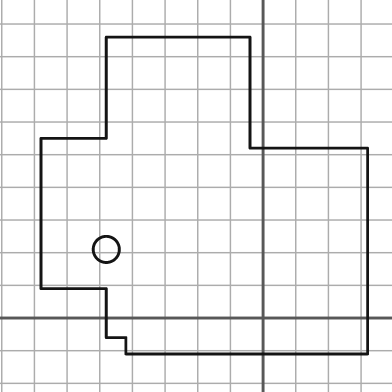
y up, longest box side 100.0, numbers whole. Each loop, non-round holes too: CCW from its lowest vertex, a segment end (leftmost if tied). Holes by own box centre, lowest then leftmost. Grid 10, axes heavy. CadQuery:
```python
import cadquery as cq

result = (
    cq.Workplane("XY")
    .moveTo(-42.0, -11.0)
    .lineTo(32.0, -11.0)
    .lineTo(32.0, 52.0)
    .lineTo(-4.0, 52.0)
    .lineTo(-4.0, 86.0)
    .lineTo(-48.0, 86.0)
    .lineTo(-48.0, 55.0)
    .lineTo(-68.0, 55.0)
    .lineTo(-68.0, 9.0)
    .lineTo(-48.0, 9.0)
    .lineTo(-48.0, -6.0)
    .lineTo(-42.0, -6.0)
    .close()
    .moveTo(-48.0, 21.0)
    .circle(4.0)
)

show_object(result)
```